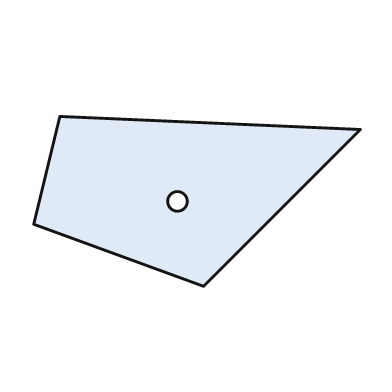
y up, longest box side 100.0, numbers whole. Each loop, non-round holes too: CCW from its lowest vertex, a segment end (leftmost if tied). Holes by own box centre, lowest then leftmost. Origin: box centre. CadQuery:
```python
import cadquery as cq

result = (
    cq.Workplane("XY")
    .moveTo(2.0, -26.0)
    .lineTo(50.0, 22.0)
    .lineTo(-42.0, 26.0)
    .lineTo(-50.0, -7.0)
    .close()
    .moveTo(-6.0, 0.0)
    .circle(3.0)
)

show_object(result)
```